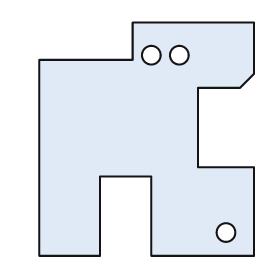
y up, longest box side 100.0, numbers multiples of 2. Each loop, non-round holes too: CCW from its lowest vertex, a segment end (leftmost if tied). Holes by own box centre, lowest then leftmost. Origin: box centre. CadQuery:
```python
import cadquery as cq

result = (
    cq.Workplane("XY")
    .moveTo(-46.0, -50.0)
    .lineTo(-20.0, -50.0)
    .lineTo(-20.0, -16.0)
    .lineTo(2.0, -16.0)
    .lineTo(2.0, -50.0)
    .lineTo(46.0, -50.0)
    .lineTo(46.0, -12.0)
    .lineTo(22.0, -12.0)
    .lineTo(22.0, 22.0)
    .lineTo(40.0, 22.0)
    .lineTo(46.0, 28.0)
    .lineTo(46.0, 50.0)
    .lineTo(-6.0, 50.0)
    .lineTo(-6.0, 34.0)
    .lineTo(-46.0, 34.0)
    .close()
    .moveTo(34.0, -40.0)
    .circle(4.0)
    .moveTo(2.0, 36.0)
    .circle(4.0)
    .moveTo(14.0, 36.0)
    .circle(4.0)
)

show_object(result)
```